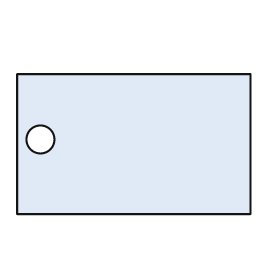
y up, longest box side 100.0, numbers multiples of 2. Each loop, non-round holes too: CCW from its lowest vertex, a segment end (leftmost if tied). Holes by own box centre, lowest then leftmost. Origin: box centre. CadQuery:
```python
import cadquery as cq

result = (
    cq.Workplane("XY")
    .moveTo(-50.0, -30.0)
    .lineTo(50.0, -30.0)
    .lineTo(50.0, 30.0)
    .lineTo(-50.0, 30.0)
    .close()
    .moveTo(-40.0, 2.0)
    .circle(6.0)
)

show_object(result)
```